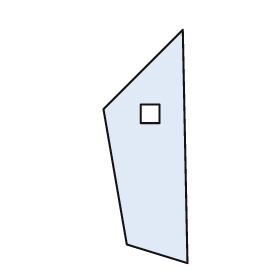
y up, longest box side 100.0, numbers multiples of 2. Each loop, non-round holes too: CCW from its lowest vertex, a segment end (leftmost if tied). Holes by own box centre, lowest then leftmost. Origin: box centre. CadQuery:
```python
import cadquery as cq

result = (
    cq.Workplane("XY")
    .moveTo(18.0, -50.0)
    .lineTo(16.0, 50.0)
    .lineTo(-18.0, 16.0)
    .lineTo(-8.0, -42.0)
    .close()
    .moveTo(-2.0, 10.0)
    .lineTo(6.0, 10.0)
    .lineTo(6.0, 18.0)
    .lineTo(-2.0, 18.0)
    .close()
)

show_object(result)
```